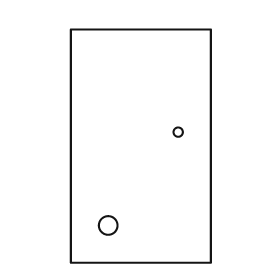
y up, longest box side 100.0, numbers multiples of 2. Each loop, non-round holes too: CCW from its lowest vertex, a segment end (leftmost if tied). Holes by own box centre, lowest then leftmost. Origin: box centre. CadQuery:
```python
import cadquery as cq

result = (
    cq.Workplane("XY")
    .moveTo(-30.0, -50.0)
    .lineTo(30.0, -50.0)
    .lineTo(30.0, 50.0)
    .lineTo(-30.0, 50.0)
    .close()
    .moveTo(-14.0, -34.0)
    .circle(4.0)
    .moveTo(16.0, 6.0)
    .circle(2.0)
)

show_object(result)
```